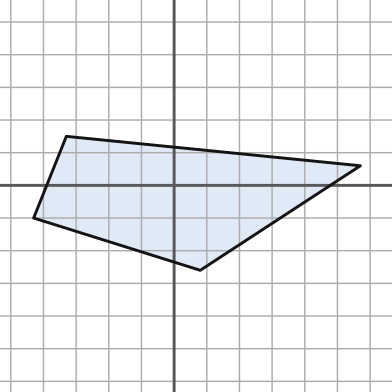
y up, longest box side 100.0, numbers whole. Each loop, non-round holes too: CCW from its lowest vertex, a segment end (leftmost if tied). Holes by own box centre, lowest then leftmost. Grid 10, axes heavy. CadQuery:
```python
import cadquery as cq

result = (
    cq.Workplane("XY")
    .moveTo(8.0, -26.0)
    .lineTo(57.0, 6.0)
    .lineTo(-33.0, 15.0)
    .lineTo(-43.0, -10.0)
    .close()
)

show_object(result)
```